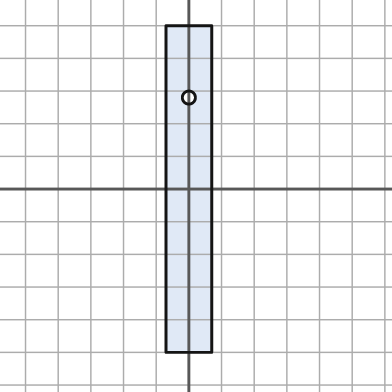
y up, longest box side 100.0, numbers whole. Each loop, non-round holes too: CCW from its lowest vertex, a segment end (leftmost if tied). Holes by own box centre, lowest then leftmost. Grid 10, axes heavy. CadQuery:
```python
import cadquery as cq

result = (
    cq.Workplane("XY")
    .moveTo(-7.0, -50.0)
    .lineTo(7.0, -50.0)
    .lineTo(7.0, 50.0)
    .lineTo(-7.0, 50.0)
    .close()
    .moveTo(0.0, 28.0)
    .circle(2.0)
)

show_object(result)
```